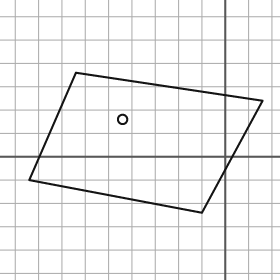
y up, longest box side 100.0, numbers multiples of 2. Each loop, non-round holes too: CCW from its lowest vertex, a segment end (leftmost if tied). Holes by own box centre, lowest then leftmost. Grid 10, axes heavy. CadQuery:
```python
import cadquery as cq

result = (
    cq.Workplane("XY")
    .moveTo(-10.0, -24.0)
    .lineTo(16.0, 24.0)
    .lineTo(-64.0, 36.0)
    .lineTo(-84.0, -10.0)
    .close()
    .moveTo(-44.0, 16.0)
    .circle(2.0)
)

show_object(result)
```